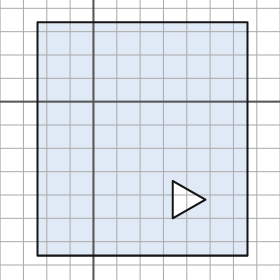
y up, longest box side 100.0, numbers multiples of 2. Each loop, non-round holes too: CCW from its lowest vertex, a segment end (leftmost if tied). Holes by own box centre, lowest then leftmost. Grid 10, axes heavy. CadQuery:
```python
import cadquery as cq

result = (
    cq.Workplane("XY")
    .moveTo(-24.0, -66.0)
    .lineTo(66.0, -66.0)
    .lineTo(66.0, 34.0)
    .lineTo(-24.0, 34.0)
    .close()
    .moveTo(34.0, -50.0)
    .lineTo(48.0, -42.0)
    .lineTo(34.0, -34.0)
    .close()
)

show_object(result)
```